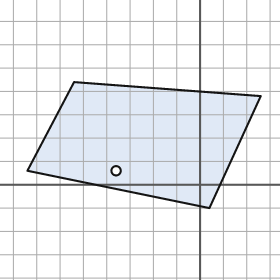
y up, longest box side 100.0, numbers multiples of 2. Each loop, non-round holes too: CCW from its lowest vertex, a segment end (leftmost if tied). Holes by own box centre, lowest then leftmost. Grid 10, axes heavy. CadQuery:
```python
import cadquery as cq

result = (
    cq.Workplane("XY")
    .moveTo(4.0, -10.0)
    .lineTo(26.0, 38.0)
    .lineTo(-54.0, 44.0)
    .lineTo(-74.0, 6.0)
    .close()
    .moveTo(-36.0, 6.0)
    .circle(2.0)
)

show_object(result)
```